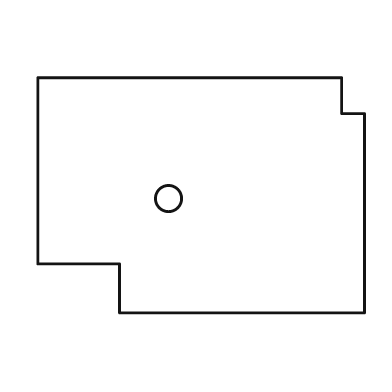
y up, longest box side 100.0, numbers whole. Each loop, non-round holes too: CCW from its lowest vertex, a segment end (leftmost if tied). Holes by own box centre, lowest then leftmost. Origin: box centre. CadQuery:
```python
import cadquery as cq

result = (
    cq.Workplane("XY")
    .moveTo(-25.0, -36.0)
    .lineTo(50.0, -36.0)
    .lineTo(50.0, 25.0)
    .lineTo(43.0, 25.0)
    .lineTo(43.0, 36.0)
    .lineTo(-50.0, 36.0)
    .lineTo(-50.0, -21.0)
    .lineTo(-25.0, -21.0)
    .close()
    .moveTo(-10.0, -1.0)
    .circle(4.0)
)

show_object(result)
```